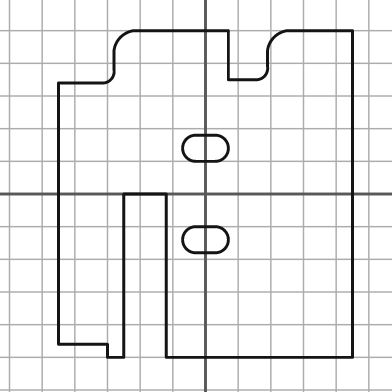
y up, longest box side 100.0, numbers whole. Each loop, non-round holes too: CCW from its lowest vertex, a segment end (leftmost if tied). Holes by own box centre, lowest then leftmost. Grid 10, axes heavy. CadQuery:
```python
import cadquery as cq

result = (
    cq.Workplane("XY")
    .moveTo(-30.0, -50.0)
    .lineTo(-25.0, -50.0)
    .lineTo(-25.0, 0.0)
    .lineTo(-12.0, 0.0)
    .lineTo(-12.0, -50.0)
    .lineTo(45.0, -50.0)
    .lineTo(45.0, 50.0)
    .lineTo(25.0, 50.0)
    .threePointArc((21.0, 48.0), (19.0, 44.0))
    .lineTo(19.0, 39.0)
    .threePointArc((18.0, 36.0), (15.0, 35.0))
    .lineTo(7.0, 35.0)
    .lineTo(7.0, 50.0)
    .lineTo(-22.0, 50.0)
    .threePointArc((-26.0, 48.0), (-28.0, 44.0))
    .lineTo(-28.0, 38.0)
    .threePointArc((-29.0, 35.0), (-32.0, 34.0))
    .lineTo(-45.0, 34.0)
    .lineTo(-45.0, -46.0)
    .lineTo(-30.0, -46.0)
    .close()
    .moveTo(-3.0, -18.0)
    .lineTo(3.0, -18.0)
    .threePointArc((7.0, -14.0), (3.0, -10.0))
    .lineTo(-3.0, -10.0)
    .threePointArc((-7.0, -14.0), (-3.0, -18.0))
    .close()
    .moveTo(-3.0, 10.0)
    .lineTo(3.0, 10.0)
    .threePointArc((7.0, 14.0), (3.0, 18.0))
    .lineTo(-3.0, 18.0)
    .threePointArc((-7.0, 14.0), (-3.0, 10.0))
    .close()
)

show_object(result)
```